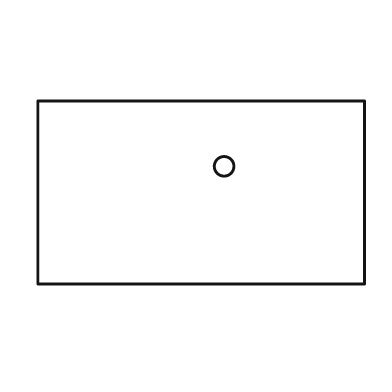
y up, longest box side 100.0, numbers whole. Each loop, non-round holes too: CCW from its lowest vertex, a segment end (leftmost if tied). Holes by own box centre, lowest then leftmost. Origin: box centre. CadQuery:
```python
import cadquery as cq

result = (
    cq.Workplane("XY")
    .moveTo(-50.0, -28.0)
    .lineTo(50.0, -28.0)
    .lineTo(50.0, 28.0)
    .lineTo(-50.0, 28.0)
    .close()
    .moveTo(7.0, 8.0)
    .circle(3.0)
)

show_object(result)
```